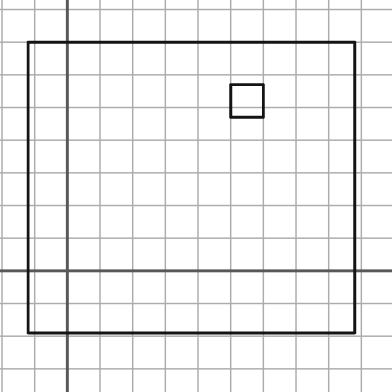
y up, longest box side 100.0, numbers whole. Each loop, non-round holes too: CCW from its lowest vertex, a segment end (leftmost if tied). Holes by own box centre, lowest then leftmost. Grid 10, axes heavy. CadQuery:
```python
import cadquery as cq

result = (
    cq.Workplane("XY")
    .moveTo(-12.0, -19.0)
    .lineTo(88.0, -19.0)
    .lineTo(88.0, 70.0)
    .lineTo(-12.0, 70.0)
    .close()
    .moveTo(50.0, 47.0)
    .lineTo(60.0, 47.0)
    .lineTo(60.0, 57.0)
    .lineTo(50.0, 57.0)
    .close()
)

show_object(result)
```